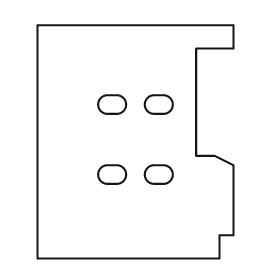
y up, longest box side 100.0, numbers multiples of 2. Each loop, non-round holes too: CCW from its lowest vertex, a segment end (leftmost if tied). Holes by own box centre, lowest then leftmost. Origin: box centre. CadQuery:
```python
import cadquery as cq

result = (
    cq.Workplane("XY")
    .moveTo(-42.0, -50.0)
    .lineTo(36.0, -50.0)
    .lineTo(36.0, -40.0)
    .lineTo(42.0, -40.0)
    .lineTo(42.0, -10.0)
    .lineTo(34.0, -6.0)
    .lineTo(26.0, -6.0)
    .lineTo(26.0, 40.0)
    .lineTo(42.0, 40.0)
    .lineTo(42.0, 50.0)
    .lineTo(-42.0, 50.0)
    .close()
    .moveTo(-12.0, -18.0)
    .lineTo(-8.0, -18.0)
    .threePointArc((-4.0, -14.0), (-8.0, -10.0))
    .lineTo(-12.0, -10.0)
    .threePointArc((-16.0, -14.0), (-12.0, -18.0))
    .close()
    .moveTo(8.0, -18.0)
    .lineTo(12.0, -18.0)
    .threePointArc((16.0, -14.0), (12.0, -10.0))
    .lineTo(8.0, -10.0)
    .threePointArc((4.0, -14.0), (8.0, -18.0))
    .close()
    .moveTo(-12.0, 12.0)
    .lineTo(-8.0, 12.0)
    .threePointArc((-4.0, 16.0), (-8.0, 20.0))
    .lineTo(-12.0, 20.0)
    .threePointArc((-16.0, 16.0), (-12.0, 12.0))
    .close()
    .moveTo(8.0, 12.0)
    .lineTo(12.0, 12.0)
    .threePointArc((16.0, 16.0), (12.0, 20.0))
    .lineTo(8.0, 20.0)
    .threePointArc((4.0, 16.0), (8.0, 12.0))
    .close()
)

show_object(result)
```